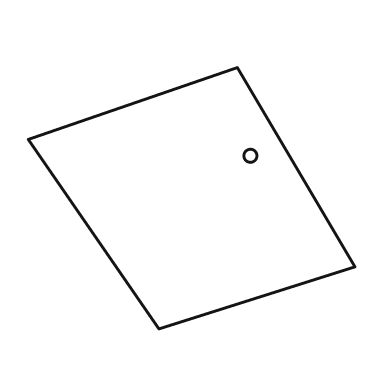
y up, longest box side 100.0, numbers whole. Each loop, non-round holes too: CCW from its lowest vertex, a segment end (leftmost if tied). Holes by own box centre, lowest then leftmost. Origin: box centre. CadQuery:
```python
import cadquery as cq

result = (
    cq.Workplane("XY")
    .moveTo(-10.0, -40.0)
    .lineTo(50.0, -21.0)
    .lineTo(14.0, 40.0)
    .lineTo(-50.0, 18.0)
    .close()
    .moveTo(18.0, 13.0)
    .circle(2.0)
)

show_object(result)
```